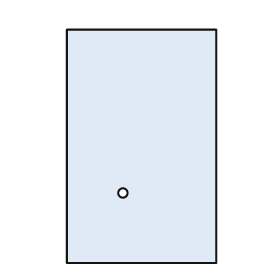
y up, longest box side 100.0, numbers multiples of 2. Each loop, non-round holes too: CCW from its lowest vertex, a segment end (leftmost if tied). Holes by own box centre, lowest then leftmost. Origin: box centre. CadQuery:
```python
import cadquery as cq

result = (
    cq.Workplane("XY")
    .moveTo(-32.0, -50.0)
    .lineTo(32.0, -50.0)
    .lineTo(32.0, 50.0)
    .lineTo(-32.0, 50.0)
    .close()
    .moveTo(-8.0, -20.0)
    .circle(2.0)
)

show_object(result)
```